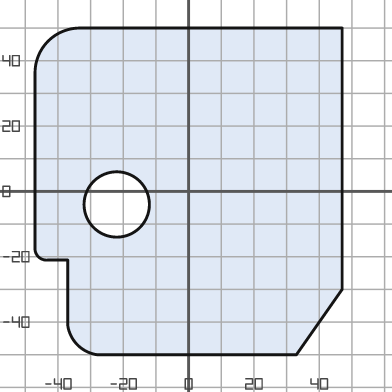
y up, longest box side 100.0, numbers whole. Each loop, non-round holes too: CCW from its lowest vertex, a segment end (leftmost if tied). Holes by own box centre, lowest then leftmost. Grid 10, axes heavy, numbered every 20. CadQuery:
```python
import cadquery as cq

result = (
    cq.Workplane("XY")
    .moveTo(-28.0, -50.0)
    .lineTo(33.0, -50.0)
    .lineTo(47.0, -30.0)
    .lineTo(47.0, 50.0)
    .lineTo(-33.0, 50.0)
    .threePointArc((-43.0, 46.0), (-47.0, 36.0))
    .lineTo(-47.0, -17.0)
    .threePointArc((-46.0, -20.0), (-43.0, -21.0))
    .lineTo(-37.0, -21.0)
    .lineTo(-37.0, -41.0)
    .threePointArc((-34.0, -47.0), (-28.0, -50.0))
    .close()
    .moveTo(-22.0, -4.0)
    .circle(10.0)
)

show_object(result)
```